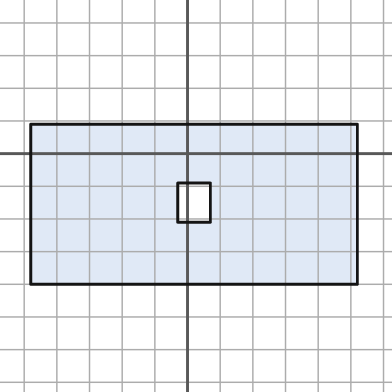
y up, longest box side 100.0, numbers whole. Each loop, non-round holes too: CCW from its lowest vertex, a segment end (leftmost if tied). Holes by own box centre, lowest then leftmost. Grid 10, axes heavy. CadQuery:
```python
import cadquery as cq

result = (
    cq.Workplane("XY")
    .moveTo(-48.0, -40.0)
    .lineTo(52.0, -40.0)
    .lineTo(52.0, 9.0)
    .lineTo(-48.0, 9.0)
    .close()
    .moveTo(-3.0, -21.0)
    .lineTo(7.0, -21.0)
    .lineTo(7.0, -9.0)
    .lineTo(-3.0, -9.0)
    .close()
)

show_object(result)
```